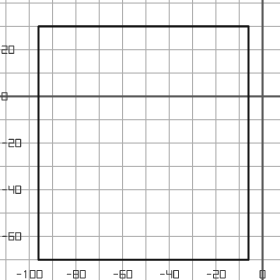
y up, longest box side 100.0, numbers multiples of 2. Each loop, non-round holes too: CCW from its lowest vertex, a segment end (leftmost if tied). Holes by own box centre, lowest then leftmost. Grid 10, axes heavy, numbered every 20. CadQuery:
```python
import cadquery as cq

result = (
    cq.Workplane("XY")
    .moveTo(-96.0, -70.0)
    .lineTo(-6.0, -70.0)
    .lineTo(-6.0, 30.0)
    .lineTo(-96.0, 30.0)
    .close()
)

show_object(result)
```